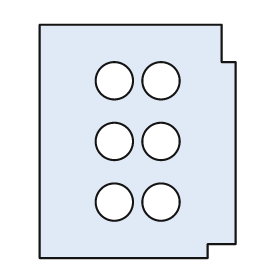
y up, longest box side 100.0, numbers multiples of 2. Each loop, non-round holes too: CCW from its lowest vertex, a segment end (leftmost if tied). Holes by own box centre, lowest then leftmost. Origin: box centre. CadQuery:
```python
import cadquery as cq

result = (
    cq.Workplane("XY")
    .moveTo(-42.0, -50.0)
    .lineTo(30.0, -50.0)
    .lineTo(30.0, -44.0)
    .lineTo(42.0, -44.0)
    .lineTo(42.0, 34.0)
    .lineTo(36.0, 34.0)
    .lineTo(36.0, 50.0)
    .lineTo(-42.0, 50.0)
    .close()
    .moveTo(-10.0, -26.0)
    .circle(8.0)
    .moveTo(10.0, -26.0)
    .circle(8.0)
    .moveTo(-10.0, 0.0)
    .circle(8.0)
    .moveTo(10.0, 0.0)
    .circle(8.0)
    .moveTo(-10.0, 26.0)
    .circle(8.0)
    .moveTo(10.0, 26.0)
    .circle(8.0)
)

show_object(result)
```